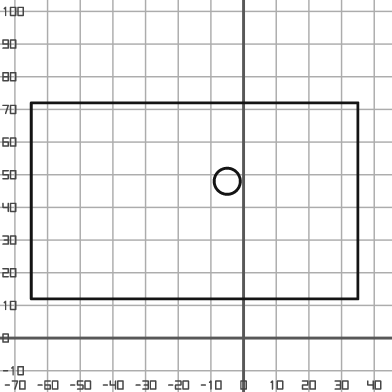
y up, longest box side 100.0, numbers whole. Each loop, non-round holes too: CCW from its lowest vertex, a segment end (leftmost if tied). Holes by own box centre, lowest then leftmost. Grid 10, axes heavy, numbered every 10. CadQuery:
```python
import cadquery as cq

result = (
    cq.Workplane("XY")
    .moveTo(-65.0, 12.0)
    .lineTo(35.0, 12.0)
    .lineTo(35.0, 72.0)
    .lineTo(-65.0, 72.0)
    .close()
    .moveTo(-5.0, 48.0)
    .circle(4.0)
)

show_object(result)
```